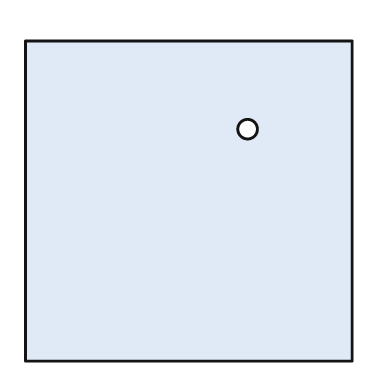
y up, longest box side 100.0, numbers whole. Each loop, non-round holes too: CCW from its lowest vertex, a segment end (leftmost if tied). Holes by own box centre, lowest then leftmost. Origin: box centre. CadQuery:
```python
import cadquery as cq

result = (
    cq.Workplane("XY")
    .moveTo(-50.0, -49.0)
    .lineTo(50.0, -49.0)
    .lineTo(50.0, 49.0)
    .lineTo(-50.0, 49.0)
    .close()
    .moveTo(18.0, 22.0)
    .circle(3.0)
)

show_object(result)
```